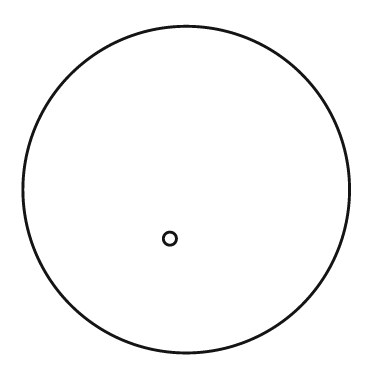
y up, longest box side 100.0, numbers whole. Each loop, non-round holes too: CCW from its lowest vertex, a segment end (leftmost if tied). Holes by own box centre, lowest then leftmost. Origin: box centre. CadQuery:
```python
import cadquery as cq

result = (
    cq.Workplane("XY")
    .moveTo(0.0, 0.0)
    .circle(50.0)
    .moveTo(-5.0, -15.0)
    .circle(2.0)
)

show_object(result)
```